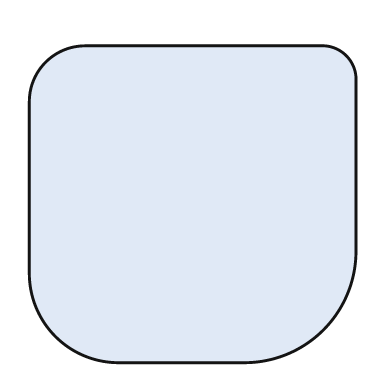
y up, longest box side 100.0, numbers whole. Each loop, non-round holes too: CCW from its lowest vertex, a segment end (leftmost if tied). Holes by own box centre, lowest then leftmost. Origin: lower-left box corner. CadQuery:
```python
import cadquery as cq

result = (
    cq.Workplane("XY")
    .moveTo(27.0, 0.0)
    .lineTo(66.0, 0.0)
    .threePointArc((90.0, 10.0), (100.0, 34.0))
    .lineTo(100.0, 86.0)
    .threePointArc((97.0, 94.0), (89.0, 97.0))
    .lineTo(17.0, 97.0)
    .threePointArc((5.0, 92.0), (0.0, 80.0))
    .lineTo(0.0, 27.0)
    .threePointArc((8.0, 8.0), (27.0, 0.0))
    .close()
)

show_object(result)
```